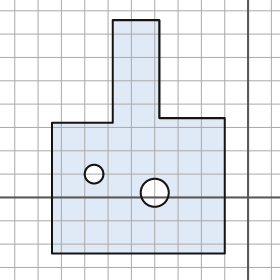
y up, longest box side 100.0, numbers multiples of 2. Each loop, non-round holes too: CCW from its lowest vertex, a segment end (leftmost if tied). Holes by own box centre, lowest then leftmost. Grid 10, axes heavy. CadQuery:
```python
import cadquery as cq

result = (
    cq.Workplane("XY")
    .moveTo(-84.0, -24.0)
    .lineTo(-10.0, -24.0)
    .lineTo(-10.0, 34.0)
    .lineTo(-38.0, 34.0)
    .lineTo(-38.0, 76.0)
    .lineTo(-58.0, 76.0)
    .lineTo(-58.0, 32.0)
    .lineTo(-84.0, 32.0)
    .close()
    .moveTo(-40.0, 2.0)
    .circle(6.0)
    .moveTo(-66.0, 10.0)
    .circle(4.0)
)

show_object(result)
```